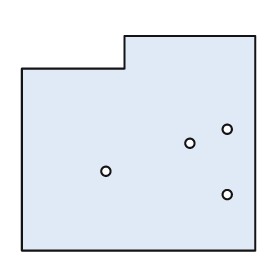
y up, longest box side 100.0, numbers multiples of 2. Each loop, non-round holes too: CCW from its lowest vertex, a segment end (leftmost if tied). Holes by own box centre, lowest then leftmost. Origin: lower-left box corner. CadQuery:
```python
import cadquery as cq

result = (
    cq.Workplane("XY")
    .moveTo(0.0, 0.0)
    .lineTo(100.0, 0.0)
    .lineTo(100.0, 92.0)
    .lineTo(44.0, 92.0)
    .lineTo(44.0, 78.0)
    .lineTo(0.0, 78.0)
    .close()
    .moveTo(88.0, 24.0)
    .circle(2.0)
    .moveTo(36.0, 34.0)
    .circle(2.0)
    .moveTo(72.0, 46.0)
    .circle(2.0)
    .moveTo(88.0, 52.0)
    .circle(2.0)
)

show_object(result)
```